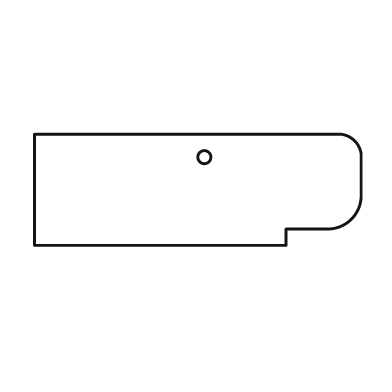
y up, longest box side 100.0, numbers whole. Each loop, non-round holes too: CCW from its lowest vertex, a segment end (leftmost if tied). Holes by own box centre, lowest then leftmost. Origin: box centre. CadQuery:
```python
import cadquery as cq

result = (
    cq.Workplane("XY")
    .moveTo(-50.0, -17.0)
    .lineTo(27.0, -17.0)
    .lineTo(27.0, -12.0)
    .lineTo(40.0, -12.0)
    .threePointArc((47.0, -9.0), (50.0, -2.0))
    .lineTo(50.0, 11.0)
    .threePointArc((48.0, 15.0), (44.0, 17.0))
    .lineTo(-50.0, 17.0)
    .close()
    .moveTo(2.0, 10.0)
    .circle(2.0)
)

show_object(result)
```